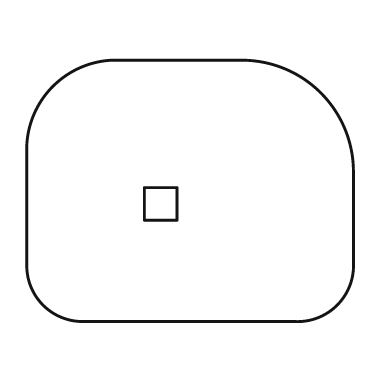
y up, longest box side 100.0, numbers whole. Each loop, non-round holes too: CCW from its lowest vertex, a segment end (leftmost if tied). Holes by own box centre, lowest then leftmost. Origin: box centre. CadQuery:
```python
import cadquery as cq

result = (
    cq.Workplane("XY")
    .moveTo(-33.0, -40.0)
    .lineTo(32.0, -40.0)
    .threePointArc((45.0, -35.0), (50.0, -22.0))
    .lineTo(50.0, 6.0)
    .threePointArc((40.0, 30.0), (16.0, 40.0))
    .lineTo(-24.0, 40.0)
    .threePointArc((-42.0, 32.0), (-50.0, 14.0))
    .lineTo(-50.0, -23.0)
    .threePointArc((-45.0, -35.0), (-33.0, -40.0))
    .close()
    .moveTo(-14.0, -9.0)
    .lineTo(-4.0, -9.0)
    .lineTo(-4.0, 1.0)
    .lineTo(-14.0, 1.0)
    .close()
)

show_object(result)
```